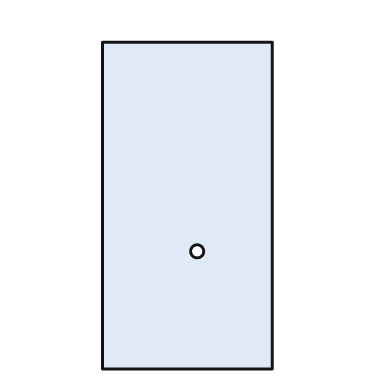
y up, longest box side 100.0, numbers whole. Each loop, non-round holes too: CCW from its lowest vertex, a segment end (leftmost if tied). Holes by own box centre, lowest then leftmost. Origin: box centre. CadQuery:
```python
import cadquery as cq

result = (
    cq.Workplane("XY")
    .moveTo(-26.0, -50.0)
    .lineTo(26.0, -50.0)
    .lineTo(26.0, 50.0)
    .lineTo(-26.0, 50.0)
    .close()
    .moveTo(3.0, -14.0)
    .circle(2.0)
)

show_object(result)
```